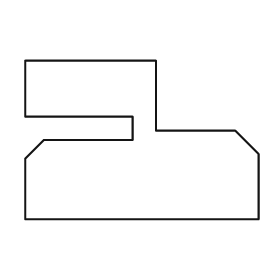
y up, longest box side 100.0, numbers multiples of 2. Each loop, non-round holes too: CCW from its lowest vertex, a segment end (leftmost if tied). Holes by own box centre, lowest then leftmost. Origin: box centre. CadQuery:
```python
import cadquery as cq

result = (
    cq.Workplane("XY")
    .moveTo(-50.0, -34.0)
    .lineTo(50.0, -34.0)
    .lineTo(50.0, -6.0)
    .lineTo(40.0, 4.0)
    .lineTo(6.0, 4.0)
    .lineTo(6.0, 34.0)
    .lineTo(-50.0, 34.0)
    .lineTo(-50.0, 10.0)
    .lineTo(-4.0, 10.0)
    .lineTo(-4.0, 0.0)
    .lineTo(-42.0, 0.0)
    .lineTo(-50.0, -8.0)
    .close()
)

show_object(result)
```